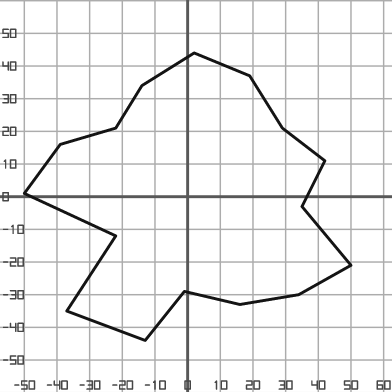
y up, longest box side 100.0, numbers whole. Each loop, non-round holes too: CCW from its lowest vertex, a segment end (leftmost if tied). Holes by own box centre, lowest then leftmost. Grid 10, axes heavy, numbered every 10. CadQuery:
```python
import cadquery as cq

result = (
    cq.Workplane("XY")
    .moveTo(-13.0, -44.0)
    .lineTo(-1.0, -29.0)
    .lineTo(16.0, -33.0)
    .lineTo(34.0, -30.0)
    .lineTo(50.0, -21.0)
    .lineTo(35.0, -3.0)
    .lineTo(42.0, 11.0)
    .lineTo(29.0, 21.0)
    .lineTo(19.0, 37.0)
    .lineTo(2.0, 44.0)
    .lineTo(-14.0, 34.0)
    .lineTo(-22.0, 21.0)
    .lineTo(-39.0, 16.0)
    .lineTo(-50.0, 1.0)
    .lineTo(-22.0, -12.0)
    .lineTo(-37.0, -35.0)
    .close()
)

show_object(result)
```